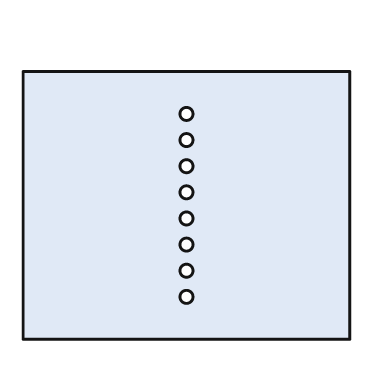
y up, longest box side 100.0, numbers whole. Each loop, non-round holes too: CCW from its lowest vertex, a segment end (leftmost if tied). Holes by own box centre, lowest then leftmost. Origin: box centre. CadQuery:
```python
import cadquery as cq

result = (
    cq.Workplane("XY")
    .moveTo(-50.0, -41.0)
    .lineTo(50.0, -41.0)
    .lineTo(50.0, 41.0)
    .lineTo(-50.0, 41.0)
    .close()
    .moveTo(0.0, -28.0)
    .circle(2.0)
    .moveTo(0.0, -20.0)
    .circle(2.0)
    .moveTo(0.0, -12.0)
    .circle(2.0)
    .moveTo(0.0, -4.0)
    .circle(2.0)
    .moveTo(0.0, 4.0)
    .circle(2.0)
    .moveTo(0.0, 12.0)
    .circle(2.0)
    .moveTo(0.0, 20.0)
    .circle(2.0)
    .moveTo(0.0, 28.0)
    .circle(2.0)
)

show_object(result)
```